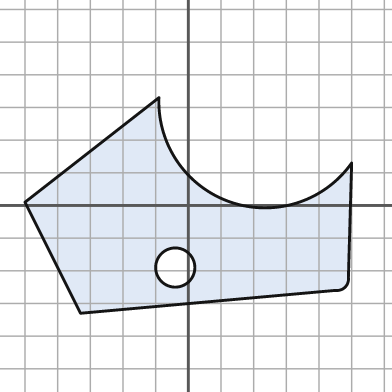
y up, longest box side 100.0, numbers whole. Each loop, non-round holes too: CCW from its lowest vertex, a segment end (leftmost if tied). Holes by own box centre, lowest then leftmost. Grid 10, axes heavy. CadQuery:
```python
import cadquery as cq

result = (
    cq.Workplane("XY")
    .moveTo(-33.0, -33.0)
    .lineTo(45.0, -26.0)
    .threePointArc((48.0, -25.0), (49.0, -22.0))
    .lineTo(50.0, 13.0)
    .threePointArc((13.0, 1.0), (-9.0, 33.0))
    .lineTo(-50.0, 1.0)
    .close()
    .moveTo(-4.0, -19.0)
    .circle(6.0)
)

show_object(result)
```